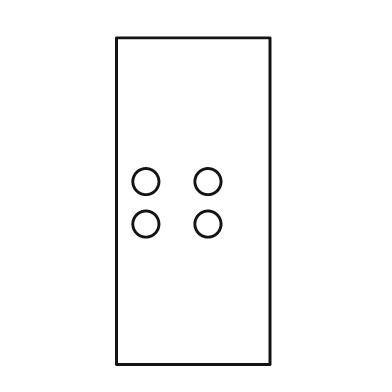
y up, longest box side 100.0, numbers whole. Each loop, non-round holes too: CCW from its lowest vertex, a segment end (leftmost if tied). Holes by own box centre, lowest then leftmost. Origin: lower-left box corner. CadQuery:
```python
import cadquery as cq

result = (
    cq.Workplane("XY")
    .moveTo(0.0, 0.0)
    .lineTo(47.0, 0.0)
    .lineTo(47.0, 100.0)
    .lineTo(0.0, 100.0)
    .close()
    .moveTo(9.0, 43.0)
    .circle(4.0)
    .moveTo(28.0, 43.0)
    .circle(4.0)
    .moveTo(9.0, 56.0)
    .circle(4.0)
    .moveTo(28.0, 56.0)
    .circle(4.0)
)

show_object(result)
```